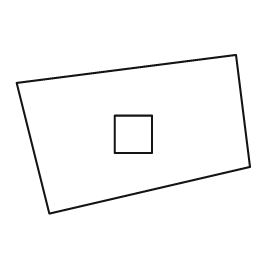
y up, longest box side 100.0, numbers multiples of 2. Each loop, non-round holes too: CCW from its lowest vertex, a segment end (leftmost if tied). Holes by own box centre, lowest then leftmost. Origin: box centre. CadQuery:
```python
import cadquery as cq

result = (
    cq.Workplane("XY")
    .moveTo(-36.0, -34.0)
    .lineTo(50.0, -14.0)
    .lineTo(44.0, 34.0)
    .lineTo(-50.0, 22.0)
    .close()
    .moveTo(-8.0, -8.0)
    .lineTo(8.0, -8.0)
    .lineTo(8.0, 8.0)
    .lineTo(-8.0, 8.0)
    .close()
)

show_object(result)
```